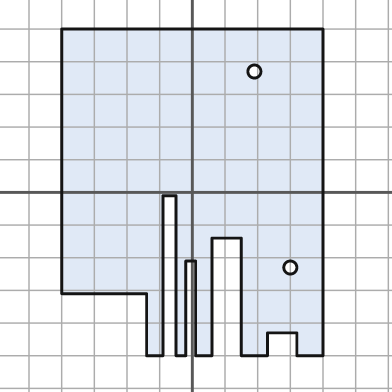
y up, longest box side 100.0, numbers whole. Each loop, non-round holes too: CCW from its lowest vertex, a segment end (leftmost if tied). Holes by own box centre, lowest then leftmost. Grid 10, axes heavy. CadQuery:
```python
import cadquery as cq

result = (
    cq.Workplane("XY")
    .moveTo(-14.0, -50.0)
    .lineTo(-9.0, -50.0)
    .lineTo(-9.0, -1.0)
    .lineTo(-5.0, -1.0)
    .lineTo(-5.0, -50.0)
    .lineTo(-2.0, -50.0)
    .lineTo(-2.0, -21.0)
    .lineTo(1.0, -21.0)
    .lineTo(1.0, -50.0)
    .lineTo(6.0, -50.0)
    .lineTo(6.0, -14.0)
    .lineTo(15.0, -14.0)
    .lineTo(15.0, -50.0)
    .lineTo(23.0, -50.0)
    .lineTo(23.0, -43.0)
    .lineTo(32.0, -43.0)
    .lineTo(32.0, -50.0)
    .lineTo(40.0, -50.0)
    .lineTo(40.0, 50.0)
    .lineTo(-40.0, 50.0)
    .lineTo(-40.0, -31.0)
    .lineTo(-14.0, -31.0)
    .close()
    .moveTo(30.0, -23.0)
    .circle(2.0)
    .moveTo(19.0, 37.0)
    .circle(2.0)
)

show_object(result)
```